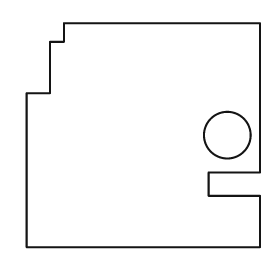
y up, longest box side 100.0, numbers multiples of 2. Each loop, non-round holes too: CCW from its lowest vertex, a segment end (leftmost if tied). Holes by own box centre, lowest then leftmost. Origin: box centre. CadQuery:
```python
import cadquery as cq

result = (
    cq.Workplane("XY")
    .moveTo(-50.0, -48.0)
    .lineTo(50.0, -48.0)
    .lineTo(50.0, -26.0)
    .lineTo(28.0, -26.0)
    .lineTo(28.0, -16.0)
    .lineTo(50.0, -16.0)
    .lineTo(50.0, 48.0)
    .lineTo(-34.0, 48.0)
    .lineTo(-34.0, 40.0)
    .lineTo(-40.0, 40.0)
    .lineTo(-40.0, 18.0)
    .lineTo(-50.0, 18.0)
    .close()
    .moveTo(36.0, 0.0)
    .circle(10.0)
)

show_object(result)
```